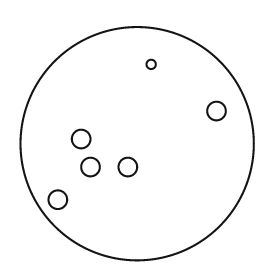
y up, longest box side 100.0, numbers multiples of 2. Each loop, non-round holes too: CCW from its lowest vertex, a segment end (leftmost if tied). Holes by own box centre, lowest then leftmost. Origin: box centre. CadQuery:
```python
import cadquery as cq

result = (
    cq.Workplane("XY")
    .moveTo(0.0, 0.0)
    .circle(50.0)
    .moveTo(-34.0, -24.0)
    .circle(4.0)
    .moveTo(-20.0, -10.0)
    .circle(4.0)
    .moveTo(-4.0, -10.0)
    .circle(4.0)
    .moveTo(-24.0, 2.0)
    .circle(4.0)
    .moveTo(34.0, 14.0)
    .circle(4.0)
    .moveTo(6.0, 34.0)
    .circle(2.0)
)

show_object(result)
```